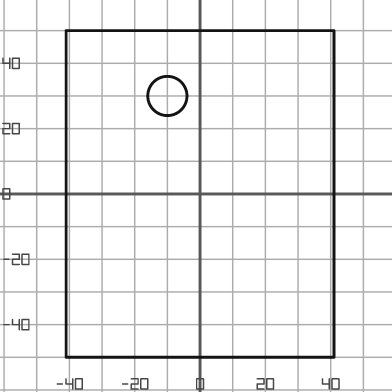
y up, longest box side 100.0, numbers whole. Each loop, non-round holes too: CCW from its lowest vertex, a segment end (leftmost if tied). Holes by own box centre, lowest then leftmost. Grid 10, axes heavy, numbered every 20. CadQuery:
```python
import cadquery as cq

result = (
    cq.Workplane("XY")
    .moveTo(-41.0, -50.0)
    .lineTo(41.0, -50.0)
    .lineTo(41.0, 50.0)
    .lineTo(-41.0, 50.0)
    .close()
    .moveTo(-10.0, 30.0)
    .circle(6.0)
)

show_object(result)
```